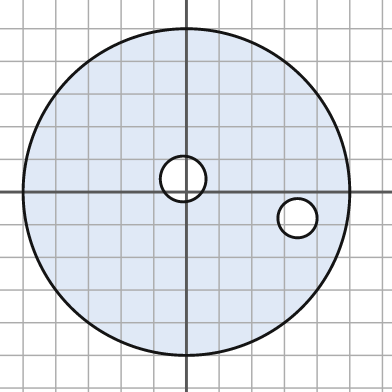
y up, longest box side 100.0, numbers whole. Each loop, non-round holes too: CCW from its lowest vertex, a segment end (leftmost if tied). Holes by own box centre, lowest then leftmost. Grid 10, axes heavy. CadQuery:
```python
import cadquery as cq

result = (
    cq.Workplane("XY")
    .moveTo(0.0, 0.0)
    .circle(50.0)
    .moveTo(34.0, -8.0)
    .circle(6.0)
    .moveTo(-1.0, 4.0)
    .circle(7.0)
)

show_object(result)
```